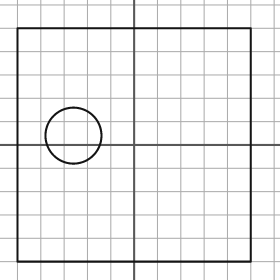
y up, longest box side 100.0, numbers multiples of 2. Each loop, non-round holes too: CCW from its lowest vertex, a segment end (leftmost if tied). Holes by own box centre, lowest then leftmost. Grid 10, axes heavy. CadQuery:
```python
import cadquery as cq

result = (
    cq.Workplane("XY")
    .moveTo(-50.0, -50.0)
    .lineTo(50.0, -50.0)
    .lineTo(50.0, 50.0)
    .lineTo(-50.0, 50.0)
    .close()
    .moveTo(-26.0, 4.0)
    .circle(12.0)
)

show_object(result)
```